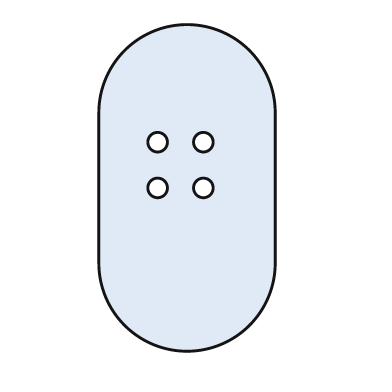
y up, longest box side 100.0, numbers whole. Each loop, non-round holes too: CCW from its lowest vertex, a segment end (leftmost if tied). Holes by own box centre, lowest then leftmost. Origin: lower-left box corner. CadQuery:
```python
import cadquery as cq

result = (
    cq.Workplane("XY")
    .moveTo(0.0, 27.0)
    .threePointArc((27.0, 0.0), (54.0, 27.0))
    .lineTo(54.0, 73.0)
    .threePointArc((27.0, 100.0), (0.0, 73.0))
    .close()
    .moveTo(18.0, 50.0)
    .circle(3.0)
    .moveTo(32.0, 50.0)
    .circle(3.0)
    .moveTo(18.0, 64.0)
    .circle(3.0)
    .moveTo(32.0, 64.0)
    .circle(3.0)
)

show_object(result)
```